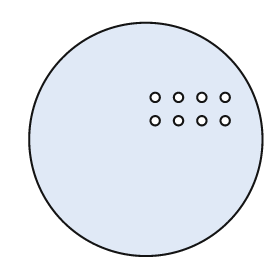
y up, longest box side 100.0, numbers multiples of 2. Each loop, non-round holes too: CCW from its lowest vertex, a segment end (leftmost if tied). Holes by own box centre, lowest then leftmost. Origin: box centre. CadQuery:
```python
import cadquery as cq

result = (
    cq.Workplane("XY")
    .moveTo(0.0, 0.0)
    .circle(50.0)
    .moveTo(4.0, 8.0)
    .circle(2.0)
    .moveTo(14.0, 8.0)
    .circle(2.0)
    .moveTo(24.0, 8.0)
    .circle(2.0)
    .moveTo(34.0, 8.0)
    .circle(2.0)
    .moveTo(4.0, 18.0)
    .circle(2.0)
    .moveTo(14.0, 18.0)
    .circle(2.0)
    .moveTo(24.0, 18.0)
    .circle(2.0)
    .moveTo(34.0, 18.0)
    .circle(2.0)
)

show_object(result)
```